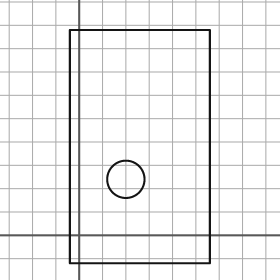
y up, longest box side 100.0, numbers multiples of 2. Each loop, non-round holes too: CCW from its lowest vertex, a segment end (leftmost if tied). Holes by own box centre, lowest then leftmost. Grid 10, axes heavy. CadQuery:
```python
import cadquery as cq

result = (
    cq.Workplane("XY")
    .moveTo(-4.0, -12.0)
    .lineTo(56.0, -12.0)
    .lineTo(56.0, 88.0)
    .lineTo(-4.0, 88.0)
    .close()
    .moveTo(20.0, 24.0)
    .circle(8.0)
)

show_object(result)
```